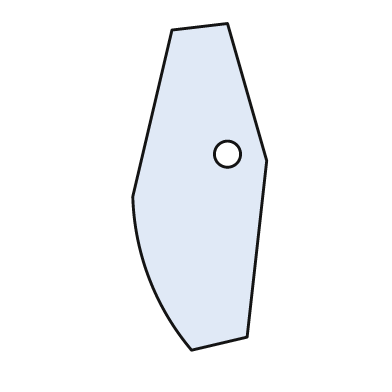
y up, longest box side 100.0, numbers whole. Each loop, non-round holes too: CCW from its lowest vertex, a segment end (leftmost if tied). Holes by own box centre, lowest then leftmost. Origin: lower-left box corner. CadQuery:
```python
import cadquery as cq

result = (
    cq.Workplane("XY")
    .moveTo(18.0, 0.0)
    .lineTo(35.0, 4.0)
    .lineTo(41.0, 58.0)
    .lineTo(29.0, 100.0)
    .lineTo(12.0, 98.0)
    .lineTo(0.0, 47.0)
    .threePointArc((5.0, 22.0), (18.0, 0.0))
    .close()
    .moveTo(29.0, 60.0)
    .circle(4.0)
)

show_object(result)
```